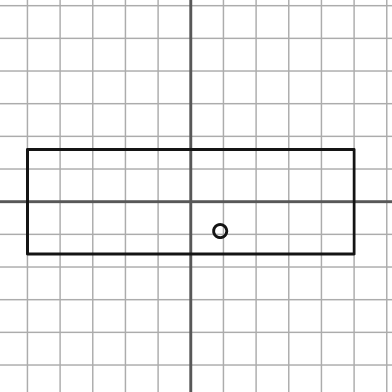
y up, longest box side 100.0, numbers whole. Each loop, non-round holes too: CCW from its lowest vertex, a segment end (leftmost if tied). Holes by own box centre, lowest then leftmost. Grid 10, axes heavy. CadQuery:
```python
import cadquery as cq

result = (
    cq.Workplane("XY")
    .moveTo(-50.0, -16.0)
    .lineTo(50.0, -16.0)
    .lineTo(50.0, 16.0)
    .lineTo(-50.0, 16.0)
    .close()
    .moveTo(9.0, -9.0)
    .circle(2.0)
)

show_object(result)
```